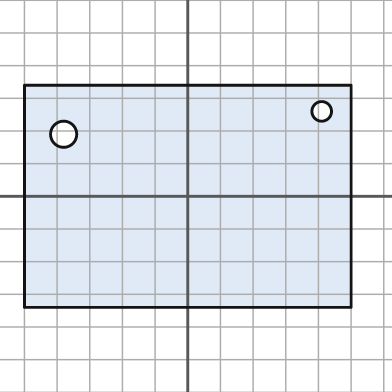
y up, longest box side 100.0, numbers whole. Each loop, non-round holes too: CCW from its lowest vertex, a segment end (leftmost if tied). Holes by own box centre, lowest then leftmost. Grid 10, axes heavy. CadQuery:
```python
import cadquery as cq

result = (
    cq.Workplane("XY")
    .moveTo(-50.0, -34.0)
    .lineTo(50.0, -34.0)
    .lineTo(50.0, 34.0)
    .lineTo(-50.0, 34.0)
    .close()
    .moveTo(-38.0, 19.0)
    .circle(4.0)
    .moveTo(41.0, 26.0)
    .circle(3.0)
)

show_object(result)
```